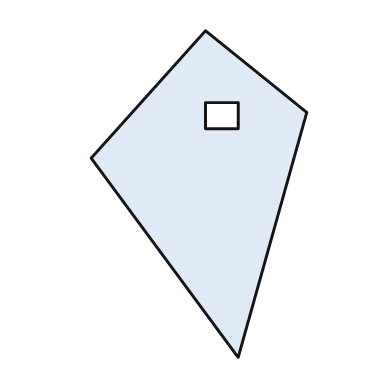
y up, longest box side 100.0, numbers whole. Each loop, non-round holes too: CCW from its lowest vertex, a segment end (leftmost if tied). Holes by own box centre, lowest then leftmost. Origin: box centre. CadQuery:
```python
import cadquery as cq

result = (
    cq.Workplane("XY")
    .moveTo(12.0, -50.0)
    .lineTo(33.0, 25.0)
    .lineTo(2.0, 50.0)
    .lineTo(-33.0, 11.0)
    .close()
    .moveTo(2.0, 20.0)
    .lineTo(12.0, 20.0)
    .lineTo(12.0, 28.0)
    .lineTo(2.0, 28.0)
    .close()
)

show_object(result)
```